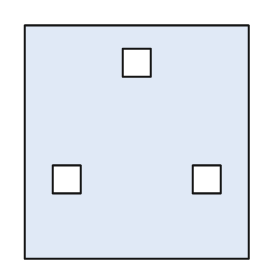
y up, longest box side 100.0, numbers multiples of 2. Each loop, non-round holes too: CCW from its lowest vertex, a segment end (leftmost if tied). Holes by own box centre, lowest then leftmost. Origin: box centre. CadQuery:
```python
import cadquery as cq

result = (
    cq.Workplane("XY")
    .moveTo(-48.0, -50.0)
    .lineTo(48.0, -50.0)
    .lineTo(48.0, 50.0)
    .lineTo(-48.0, 50.0)
    .close()
    .moveTo(-36.0, -22.0)
    .lineTo(-24.0, -22.0)
    .lineTo(-24.0, -10.0)
    .lineTo(-36.0, -10.0)
    .close()
    .moveTo(24.0, -22.0)
    .lineTo(36.0, -22.0)
    .lineTo(36.0, -10.0)
    .lineTo(24.0, -10.0)
    .close()
    .moveTo(-6.0, 28.0)
    .lineTo(6.0, 28.0)
    .lineTo(6.0, 40.0)
    .lineTo(-6.0, 40.0)
    .close()
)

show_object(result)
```